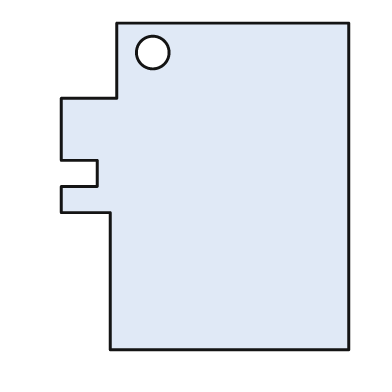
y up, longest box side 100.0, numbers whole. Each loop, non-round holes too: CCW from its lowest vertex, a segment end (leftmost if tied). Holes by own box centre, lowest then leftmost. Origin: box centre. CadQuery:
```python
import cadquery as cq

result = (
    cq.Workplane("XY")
    .moveTo(-29.0, -50.0)
    .lineTo(44.0, -50.0)
    .lineTo(44.0, 50.0)
    .lineTo(-27.0, 50.0)
    .lineTo(-27.0, 27.0)
    .lineTo(-44.0, 27.0)
    .lineTo(-44.0, 8.0)
    .lineTo(-33.0, 8.0)
    .lineTo(-33.0, 0.0)
    .lineTo(-44.0, 0.0)
    .lineTo(-44.0, -8.0)
    .lineTo(-29.0, -8.0)
    .close()
    .moveTo(-16.0, 41.0)
    .circle(5.0)
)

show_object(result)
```